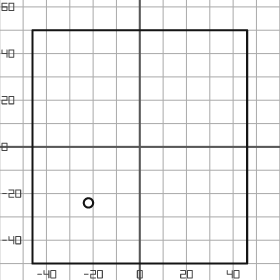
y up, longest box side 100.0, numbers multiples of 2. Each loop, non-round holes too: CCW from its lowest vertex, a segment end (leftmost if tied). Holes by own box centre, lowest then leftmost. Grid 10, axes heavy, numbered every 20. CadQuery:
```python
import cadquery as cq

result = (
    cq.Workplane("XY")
    .moveTo(-46.0, -50.0)
    .lineTo(46.0, -50.0)
    .lineTo(46.0, 50.0)
    .lineTo(-46.0, 50.0)
    .close()
    .moveTo(-22.0, -24.0)
    .circle(2.0)
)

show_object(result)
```